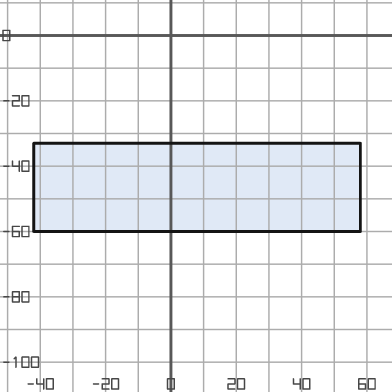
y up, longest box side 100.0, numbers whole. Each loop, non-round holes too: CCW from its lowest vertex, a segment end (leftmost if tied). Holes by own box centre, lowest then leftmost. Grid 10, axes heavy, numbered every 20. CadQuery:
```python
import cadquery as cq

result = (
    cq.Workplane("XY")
    .moveTo(-42.0, -60.0)
    .lineTo(58.0, -60.0)
    .lineTo(58.0, -33.0)
    .lineTo(-42.0, -33.0)
    .close()
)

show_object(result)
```